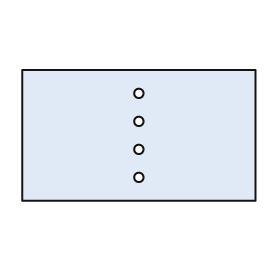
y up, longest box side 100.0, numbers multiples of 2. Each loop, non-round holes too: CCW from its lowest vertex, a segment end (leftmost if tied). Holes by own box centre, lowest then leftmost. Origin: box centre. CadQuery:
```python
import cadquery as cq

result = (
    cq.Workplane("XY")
    .moveTo(-50.0, -28.0)
    .lineTo(50.0, -28.0)
    .lineTo(50.0, 28.0)
    .lineTo(-50.0, 28.0)
    .close()
    .moveTo(0.0, -18.0)
    .circle(2.0)
    .moveTo(0.0, -6.0)
    .circle(2.0)
    .moveTo(0.0, 6.0)
    .circle(2.0)
    .moveTo(0.0, 18.0)
    .circle(2.0)
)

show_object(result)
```